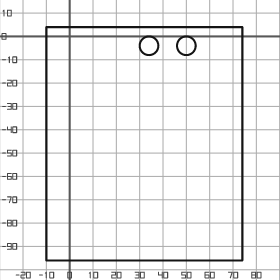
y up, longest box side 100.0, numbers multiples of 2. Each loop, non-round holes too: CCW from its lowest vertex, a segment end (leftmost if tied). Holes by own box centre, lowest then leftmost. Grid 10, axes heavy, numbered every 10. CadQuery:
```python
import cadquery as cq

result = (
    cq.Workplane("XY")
    .moveTo(-10.0, -96.0)
    .lineTo(74.0, -96.0)
    .lineTo(74.0, 4.0)
    .lineTo(-10.0, 4.0)
    .close()
    .moveTo(34.0, -4.0)
    .circle(4.0)
    .moveTo(50.0, -4.0)
    .circle(4.0)
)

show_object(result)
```